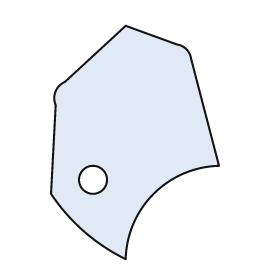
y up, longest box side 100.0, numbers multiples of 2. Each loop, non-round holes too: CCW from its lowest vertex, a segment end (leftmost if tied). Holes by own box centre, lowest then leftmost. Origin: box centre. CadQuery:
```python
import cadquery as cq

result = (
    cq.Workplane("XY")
    .moveTo(-4.0, -50.0)
    .threePointArc((8.0, -22.0), (36.0, -10.0))
    .lineTo(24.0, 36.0)
    .threePointArc((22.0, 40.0), (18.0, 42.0))
    .lineTo(-4.0, 50.0)
    .lineTo(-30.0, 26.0)
    .threePointArc((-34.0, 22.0), (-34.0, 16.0))
    .lineTo(-36.0, -22.0)
    .threePointArc((-22.0, -38.0), (-4.0, -50.0))
    .close()
    .moveTo(-18.0, -16.0)
    .circle(6.0)
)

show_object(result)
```